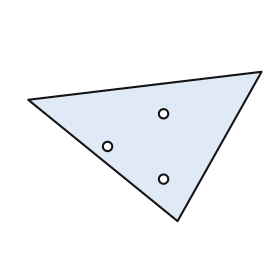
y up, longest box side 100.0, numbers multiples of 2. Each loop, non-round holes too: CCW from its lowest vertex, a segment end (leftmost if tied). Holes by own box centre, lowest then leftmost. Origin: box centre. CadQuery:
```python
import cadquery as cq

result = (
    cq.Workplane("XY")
    .moveTo(14.0, -32.0)
    .lineTo(50.0, 32.0)
    .lineTo(-50.0, 20.0)
    .close()
    .moveTo(8.0, -14.0)
    .circle(2.0)
    .moveTo(-16.0, 0.0)
    .circle(2.0)
    .moveTo(8.0, 14.0)
    .circle(2.0)
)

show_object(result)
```